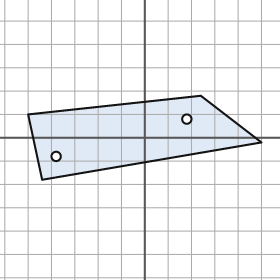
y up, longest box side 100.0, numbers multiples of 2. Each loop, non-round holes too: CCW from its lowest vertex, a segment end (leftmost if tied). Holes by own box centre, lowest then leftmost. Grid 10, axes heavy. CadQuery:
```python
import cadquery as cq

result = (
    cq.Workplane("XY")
    .moveTo(-44.0, -18.0)
    .lineTo(50.0, -2.0)
    .lineTo(24.0, 18.0)
    .lineTo(-50.0, 10.0)
    .close()
    .moveTo(-38.0, -8.0)
    .circle(2.0)
    .moveTo(18.0, 8.0)
    .circle(2.0)
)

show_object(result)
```